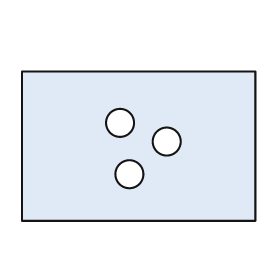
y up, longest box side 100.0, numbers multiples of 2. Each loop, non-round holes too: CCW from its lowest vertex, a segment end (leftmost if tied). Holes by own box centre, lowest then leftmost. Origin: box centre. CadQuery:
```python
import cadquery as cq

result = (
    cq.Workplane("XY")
    .moveTo(-50.0, -32.0)
    .lineTo(50.0, -32.0)
    .lineTo(50.0, 32.0)
    .lineTo(-50.0, 32.0)
    .close()
    .moveTo(-4.0, -12.0)
    .circle(6.0)
    .moveTo(12.0, 2.0)
    .circle(6.0)
    .moveTo(-8.0, 10.0)
    .circle(6.0)
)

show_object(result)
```